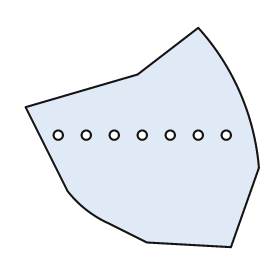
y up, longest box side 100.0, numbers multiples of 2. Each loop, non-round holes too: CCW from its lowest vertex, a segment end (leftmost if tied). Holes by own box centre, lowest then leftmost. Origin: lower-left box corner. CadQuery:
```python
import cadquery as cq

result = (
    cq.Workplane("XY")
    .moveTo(88.0, 0.0)
    .lineTo(100.0, 34.0)
    .threePointArc((92.0, 66.0), (74.0, 94.0))
    .lineTo(48.0, 74.0)
    .lineTo(0.0, 60.0)
    .lineTo(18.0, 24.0)
    .threePointArc((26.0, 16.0), (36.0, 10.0))
    .lineTo(52.0, 2.0)
    .close()
    .moveTo(14.0, 48.0)
    .circle(2.0)
    .moveTo(26.0, 48.0)
    .circle(2.0)
    .moveTo(38.0, 48.0)
    .circle(2.0)
    .moveTo(50.0, 48.0)
    .circle(2.0)
    .moveTo(62.0, 48.0)
    .circle(2.0)
    .moveTo(74.0, 48.0)
    .circle(2.0)
    .moveTo(86.0, 48.0)
    .circle(2.0)
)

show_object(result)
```